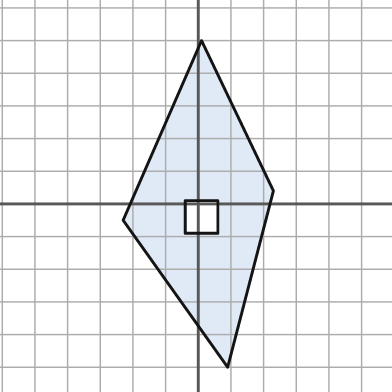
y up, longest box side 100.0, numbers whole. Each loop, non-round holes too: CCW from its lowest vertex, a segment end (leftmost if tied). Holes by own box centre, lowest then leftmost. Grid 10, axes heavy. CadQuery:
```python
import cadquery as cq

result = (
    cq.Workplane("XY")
    .moveTo(9.0, -50.0)
    .lineTo(23.0, 4.0)
    .lineTo(1.0, 50.0)
    .lineTo(-23.0, -5.0)
    .close()
    .moveTo(-4.0, -9.0)
    .lineTo(6.0, -9.0)
    .lineTo(6.0, 1.0)
    .lineTo(-4.0, 1.0)
    .close()
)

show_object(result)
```